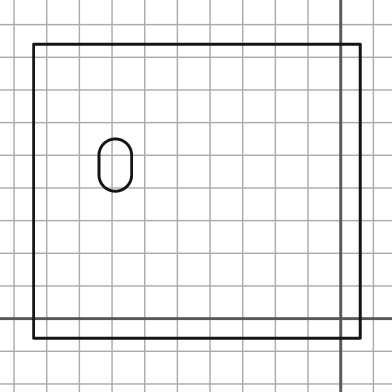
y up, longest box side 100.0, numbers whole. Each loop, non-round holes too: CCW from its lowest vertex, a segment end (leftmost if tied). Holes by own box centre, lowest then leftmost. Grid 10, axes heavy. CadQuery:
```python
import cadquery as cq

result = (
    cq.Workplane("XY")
    .moveTo(-94.0, -6.0)
    .lineTo(6.0, -6.0)
    .lineTo(6.0, 84.0)
    .lineTo(-94.0, 84.0)
    .close()
    .moveTo(-74.0, 44.0)
    .threePointArc((-69.0, 39.0), (-64.0, 44.0))
    .lineTo(-64.0, 50.0)
    .threePointArc((-69.0, 55.0), (-74.0, 50.0))
    .close()
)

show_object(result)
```